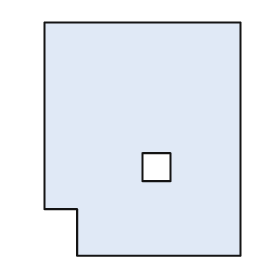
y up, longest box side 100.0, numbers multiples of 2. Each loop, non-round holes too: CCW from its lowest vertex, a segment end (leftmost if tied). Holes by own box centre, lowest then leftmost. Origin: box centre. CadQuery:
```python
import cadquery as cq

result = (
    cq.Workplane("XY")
    .moveTo(-28.0, -50.0)
    .lineTo(42.0, -50.0)
    .lineTo(42.0, 50.0)
    .lineTo(-42.0, 50.0)
    .lineTo(-42.0, -30.0)
    .lineTo(-28.0, -30.0)
    .close()
    .moveTo(0.0, -18.0)
    .lineTo(12.0, -18.0)
    .lineTo(12.0, -6.0)
    .lineTo(0.0, -6.0)
    .close()
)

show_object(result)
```